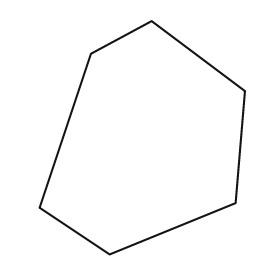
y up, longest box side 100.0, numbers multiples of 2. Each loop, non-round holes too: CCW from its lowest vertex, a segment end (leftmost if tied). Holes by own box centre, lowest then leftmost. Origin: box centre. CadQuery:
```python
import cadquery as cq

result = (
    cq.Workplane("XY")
    .moveTo(-14.0, -50.0)
    .lineTo(40.0, -28.0)
    .lineTo(44.0, 20.0)
    .lineTo(4.0, 50.0)
    .lineTo(-22.0, 36.0)
    .lineTo(-44.0, -30.0)
    .close()
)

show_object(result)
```